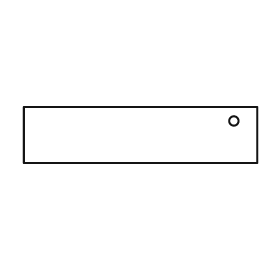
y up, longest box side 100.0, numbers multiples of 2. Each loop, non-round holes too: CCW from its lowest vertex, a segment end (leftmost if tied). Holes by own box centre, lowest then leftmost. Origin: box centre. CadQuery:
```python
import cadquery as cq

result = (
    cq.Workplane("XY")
    .moveTo(-50.0, -12.0)
    .lineTo(50.0, -12.0)
    .lineTo(50.0, 12.0)
    .lineTo(-50.0, 12.0)
    .close()
    .moveTo(40.0, 6.0)
    .circle(2.0)
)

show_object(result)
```